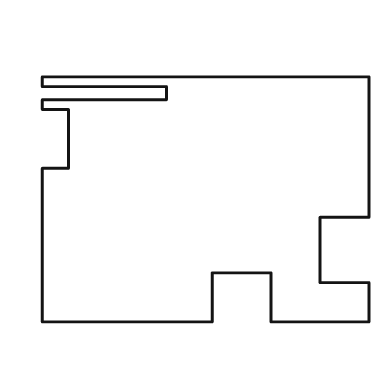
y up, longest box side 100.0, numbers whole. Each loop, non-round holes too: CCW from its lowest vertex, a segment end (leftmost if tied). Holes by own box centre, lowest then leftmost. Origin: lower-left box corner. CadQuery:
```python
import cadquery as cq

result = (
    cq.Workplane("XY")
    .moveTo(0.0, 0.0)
    .lineTo(52.0, 0.0)
    .lineTo(52.0, 15.0)
    .lineTo(70.0, 15.0)
    .lineTo(70.0, 0.0)
    .lineTo(100.0, 0.0)
    .lineTo(100.0, 12.0)
    .lineTo(85.0, 12.0)
    .lineTo(85.0, 32.0)
    .lineTo(100.0, 32.0)
    .lineTo(100.0, 75.0)
    .lineTo(0.0, 75.0)
    .lineTo(0.0, 72.0)
    .lineTo(38.0, 72.0)
    .lineTo(38.0, 68.0)
    .lineTo(0.0, 68.0)
    .lineTo(0.0, 65.0)
    .lineTo(8.0, 65.0)
    .lineTo(8.0, 47.0)
    .lineTo(0.0, 47.0)
    .close()
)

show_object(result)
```